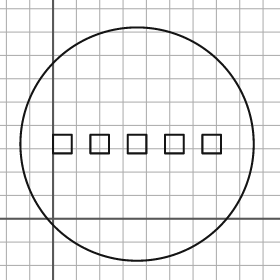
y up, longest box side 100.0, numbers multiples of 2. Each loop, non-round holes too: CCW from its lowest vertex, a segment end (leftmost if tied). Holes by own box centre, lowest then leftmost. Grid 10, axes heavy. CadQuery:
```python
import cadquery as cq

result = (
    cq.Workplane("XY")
    .moveTo(36.0, 32.0)
    .circle(50.0)
    .moveTo(0.0, 28.0)
    .lineTo(8.0, 28.0)
    .lineTo(8.0, 36.0)
    .lineTo(0.0, 36.0)
    .close()
    .moveTo(16.0, 28.0)
    .lineTo(24.0, 28.0)
    .lineTo(24.0, 36.0)
    .lineTo(16.0, 36.0)
    .close()
    .moveTo(32.0, 28.0)
    .lineTo(40.0, 28.0)
    .lineTo(40.0, 36.0)
    .lineTo(32.0, 36.0)
    .close()
    .moveTo(48.0, 28.0)
    .lineTo(56.0, 28.0)
    .lineTo(56.0, 36.0)
    .lineTo(48.0, 36.0)
    .close()
    .moveTo(64.0, 28.0)
    .lineTo(72.0, 28.0)
    .lineTo(72.0, 36.0)
    .lineTo(64.0, 36.0)
    .close()
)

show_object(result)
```